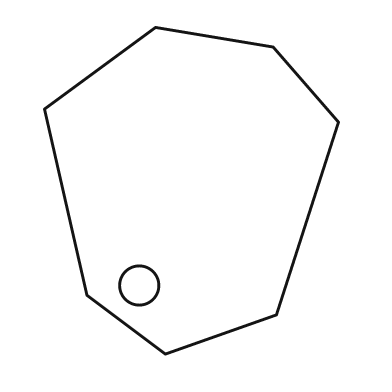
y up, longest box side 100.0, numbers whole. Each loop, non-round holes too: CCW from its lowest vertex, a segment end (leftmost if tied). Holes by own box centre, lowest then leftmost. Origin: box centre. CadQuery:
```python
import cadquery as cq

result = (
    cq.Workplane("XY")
    .moveTo(-8.0, -50.0)
    .lineTo(26.0, -38.0)
    .lineTo(45.0, 21.0)
    .lineTo(25.0, 44.0)
    .lineTo(-11.0, 50.0)
    .lineTo(-45.0, 25.0)
    .lineTo(-32.0, -32.0)
    .close()
    .moveTo(-16.0, -29.0)
    .circle(6.0)
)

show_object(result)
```